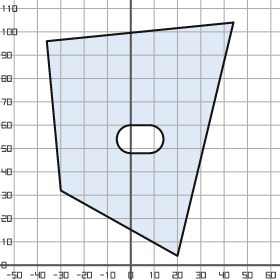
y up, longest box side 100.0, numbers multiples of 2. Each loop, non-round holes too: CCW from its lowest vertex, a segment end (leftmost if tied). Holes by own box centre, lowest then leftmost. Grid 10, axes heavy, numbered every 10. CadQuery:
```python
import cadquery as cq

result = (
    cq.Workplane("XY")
    .moveTo(20.0, 4.0)
    .lineTo(44.0, 104.0)
    .lineTo(-36.0, 96.0)
    .lineTo(-30.0, 32.0)
    .close()
    .moveTo(0.0, 48.0)
    .lineTo(8.0, 48.0)
    .threePointArc((14.0, 54.0), (8.0, 60.0))
    .lineTo(0.0, 60.0)
    .threePointArc((-6.0, 54.0), (0.0, 48.0))
    .close()
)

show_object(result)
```